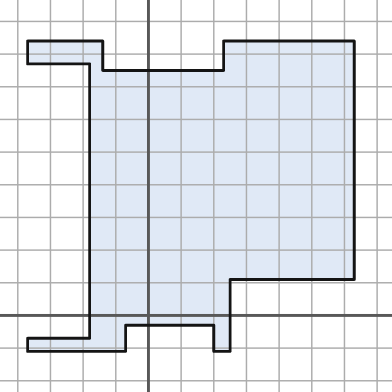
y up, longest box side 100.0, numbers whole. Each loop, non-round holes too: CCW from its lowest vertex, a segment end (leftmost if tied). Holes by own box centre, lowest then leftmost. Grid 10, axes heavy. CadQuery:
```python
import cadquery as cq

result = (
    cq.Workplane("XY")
    .moveTo(-37.0, -11.0)
    .lineTo(-7.0, -11.0)
    .lineTo(-7.0, -3.0)
    .lineTo(20.0, -3.0)
    .lineTo(20.0, -11.0)
    .lineTo(25.0, -11.0)
    .lineTo(25.0, 11.0)
    .lineTo(63.0, 11.0)
    .lineTo(63.0, 84.0)
    .lineTo(23.0, 84.0)
    .lineTo(23.0, 75.0)
    .lineTo(-14.0, 75.0)
    .lineTo(-14.0, 84.0)
    .lineTo(-37.0, 84.0)
    .lineTo(-37.0, 77.0)
    .lineTo(-18.0, 77.0)
    .lineTo(-18.0, -7.0)
    .lineTo(-37.0, -7.0)
    .close()
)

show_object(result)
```